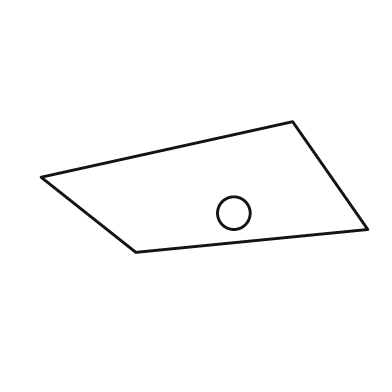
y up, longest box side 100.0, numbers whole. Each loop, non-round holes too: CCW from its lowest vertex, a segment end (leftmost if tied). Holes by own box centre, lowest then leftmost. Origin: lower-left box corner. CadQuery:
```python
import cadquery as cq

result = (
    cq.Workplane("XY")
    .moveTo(29.0, 0.0)
    .lineTo(100.0, 7.0)
    .lineTo(77.0, 40.0)
    .lineTo(0.0, 23.0)
    .close()
    .moveTo(59.0, 12.0)
    .circle(5.0)
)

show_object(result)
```